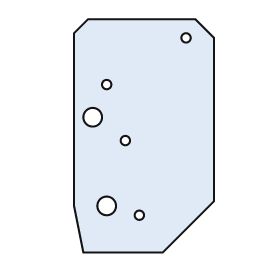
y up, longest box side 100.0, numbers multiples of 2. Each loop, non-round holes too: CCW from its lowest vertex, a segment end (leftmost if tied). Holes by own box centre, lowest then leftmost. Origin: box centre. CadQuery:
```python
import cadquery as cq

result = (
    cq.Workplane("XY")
    .moveTo(-26.0, -50.0)
    .lineTo(8.0, -50.0)
    .lineTo(30.0, -28.0)
    .lineTo(30.0, 42.0)
    .lineTo(22.0, 50.0)
    .lineTo(-24.0, 50.0)
    .lineTo(-30.0, 44.0)
    .lineTo(-30.0, -30.0)
    .close()
    .moveTo(-2.0, -34.0)
    .circle(2.0)
    .moveTo(-16.0, -30.0)
    .circle(4.0)
    .moveTo(-8.0, -2.0)
    .circle(2.0)
    .moveTo(-22.0, 8.0)
    .circle(4.0)
    .moveTo(-16.0, 22.0)
    .circle(2.0)
    .moveTo(18.0, 42.0)
    .circle(2.0)
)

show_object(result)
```